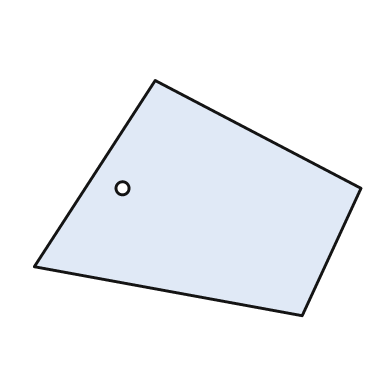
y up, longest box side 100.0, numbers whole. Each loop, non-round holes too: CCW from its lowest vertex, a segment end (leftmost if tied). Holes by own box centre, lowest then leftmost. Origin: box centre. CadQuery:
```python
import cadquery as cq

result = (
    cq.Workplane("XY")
    .moveTo(32.0, -36.0)
    .lineTo(50.0, 3.0)
    .lineTo(-13.0, 36.0)
    .lineTo(-50.0, -21.0)
    .close()
    .moveTo(-23.0, 3.0)
    .circle(2.0)
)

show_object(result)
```